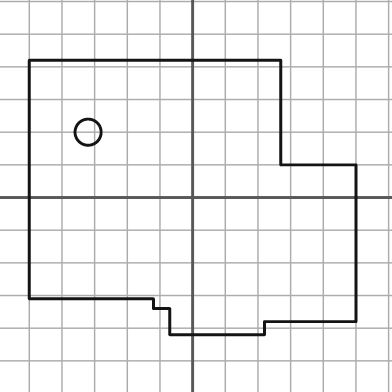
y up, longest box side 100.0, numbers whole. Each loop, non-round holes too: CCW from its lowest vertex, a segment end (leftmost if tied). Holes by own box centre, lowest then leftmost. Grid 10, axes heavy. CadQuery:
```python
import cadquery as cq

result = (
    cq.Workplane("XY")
    .moveTo(-7.0, -42.0)
    .lineTo(22.0, -42.0)
    .lineTo(22.0, -38.0)
    .lineTo(50.0, -38.0)
    .lineTo(50.0, 10.0)
    .lineTo(27.0, 10.0)
    .lineTo(27.0, 42.0)
    .lineTo(-50.0, 42.0)
    .lineTo(-50.0, -31.0)
    .lineTo(-12.0, -31.0)
    .lineTo(-12.0, -34.0)
    .lineTo(-7.0, -34.0)
    .close()
    .moveTo(-32.0, 20.0)
    .circle(4.0)
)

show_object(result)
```